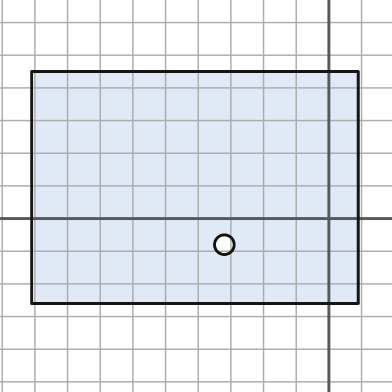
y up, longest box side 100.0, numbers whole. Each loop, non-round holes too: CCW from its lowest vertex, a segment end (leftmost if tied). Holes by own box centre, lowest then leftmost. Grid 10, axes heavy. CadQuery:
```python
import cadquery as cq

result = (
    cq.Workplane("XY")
    .moveTo(-91.0, -26.0)
    .lineTo(9.0, -26.0)
    .lineTo(9.0, 45.0)
    .lineTo(-91.0, 45.0)
    .close()
    .moveTo(-32.0, -8.0)
    .circle(3.0)
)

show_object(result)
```